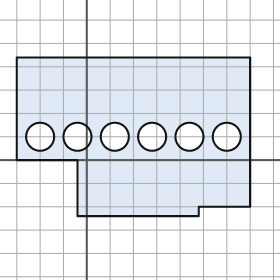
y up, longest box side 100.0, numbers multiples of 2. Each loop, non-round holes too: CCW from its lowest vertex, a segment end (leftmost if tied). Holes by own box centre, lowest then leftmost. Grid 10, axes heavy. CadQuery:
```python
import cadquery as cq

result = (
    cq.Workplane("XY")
    .moveTo(-4.0, -24.0)
    .lineTo(48.0, -24.0)
    .lineTo(48.0, -20.0)
    .lineTo(70.0, -20.0)
    .lineTo(70.0, 44.0)
    .lineTo(-30.0, 44.0)
    .lineTo(-30.0, 0.0)
    .lineTo(-4.0, 0.0)
    .close()
    .moveTo(-20.0, 10.0)
    .circle(6.0)
    .moveTo(-4.0, 10.0)
    .circle(6.0)
    .moveTo(12.0, 10.0)
    .circle(6.0)
    .moveTo(28.0, 10.0)
    .circle(6.0)
    .moveTo(44.0, 10.0)
    .circle(6.0)
    .moveTo(60.0, 10.0)
    .circle(6.0)
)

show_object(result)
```